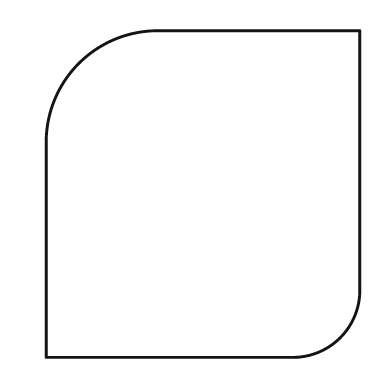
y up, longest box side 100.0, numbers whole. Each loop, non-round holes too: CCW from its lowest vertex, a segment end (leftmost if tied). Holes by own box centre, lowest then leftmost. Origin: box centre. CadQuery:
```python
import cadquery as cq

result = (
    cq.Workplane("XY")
    .moveTo(-48.0, -50.0)
    .lineTo(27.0, -50.0)
    .threePointArc((42.0, -44.0), (48.0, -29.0))
    .lineTo(48.0, 50.0)
    .lineTo(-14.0, 50.0)
    .threePointArc((-38.0, 40.0), (-48.0, 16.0))
    .close()
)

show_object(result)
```